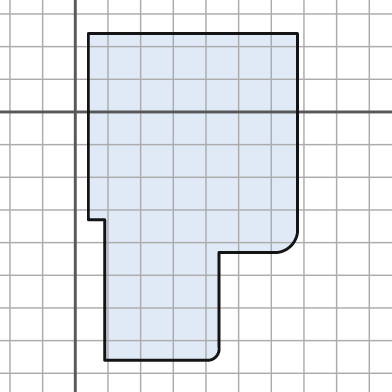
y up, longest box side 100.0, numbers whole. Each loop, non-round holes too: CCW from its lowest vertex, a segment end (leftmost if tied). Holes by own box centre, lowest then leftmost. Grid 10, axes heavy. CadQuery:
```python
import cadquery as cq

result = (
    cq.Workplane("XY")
    .moveTo(9.0, -76.0)
    .lineTo(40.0, -76.0)
    .threePointArc((43.0, -75.0), (44.0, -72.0))
    .lineTo(44.0, -43.0)
    .lineTo(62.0, -43.0)
    .threePointArc((66.0, -41.0), (68.0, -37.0))
    .lineTo(68.0, 24.0)
    .lineTo(4.0, 24.0)
    .lineTo(4.0, -33.0)
    .lineTo(9.0, -33.0)
    .close()
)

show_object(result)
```